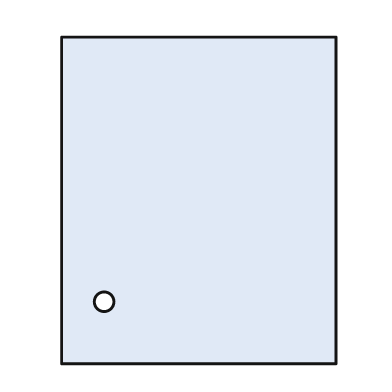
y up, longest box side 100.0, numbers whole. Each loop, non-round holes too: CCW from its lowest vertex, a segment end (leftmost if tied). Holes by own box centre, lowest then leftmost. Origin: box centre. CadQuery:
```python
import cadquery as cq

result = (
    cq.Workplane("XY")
    .moveTo(-42.0, -50.0)
    .lineTo(42.0, -50.0)
    .lineTo(42.0, 50.0)
    .lineTo(-42.0, 50.0)
    .close()
    .moveTo(-29.0, -31.0)
    .circle(3.0)
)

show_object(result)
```